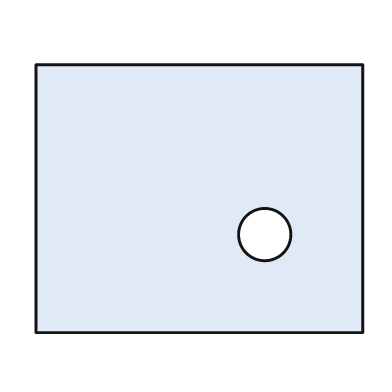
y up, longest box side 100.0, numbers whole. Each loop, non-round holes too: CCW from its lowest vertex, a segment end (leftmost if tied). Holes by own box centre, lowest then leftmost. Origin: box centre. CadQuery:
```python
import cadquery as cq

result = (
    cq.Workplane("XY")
    .moveTo(-50.0, -41.0)
    .lineTo(50.0, -41.0)
    .lineTo(50.0, 41.0)
    .lineTo(-50.0, 41.0)
    .close()
    .moveTo(20.0, -11.0)
    .circle(8.0)
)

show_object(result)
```